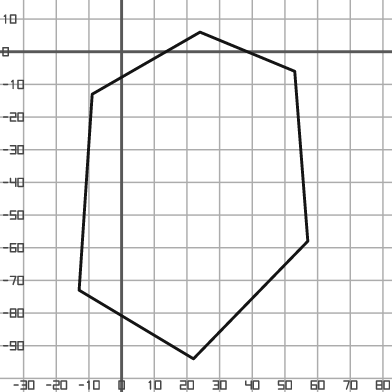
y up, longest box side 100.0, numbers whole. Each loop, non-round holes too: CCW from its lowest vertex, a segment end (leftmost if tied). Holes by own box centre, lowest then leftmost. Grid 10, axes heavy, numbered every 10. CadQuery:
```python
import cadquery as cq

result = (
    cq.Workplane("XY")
    .moveTo(22.0, -94.0)
    .lineTo(57.0, -58.0)
    .lineTo(53.0, -6.0)
    .lineTo(24.0, 6.0)
    .lineTo(-9.0, -13.0)
    .lineTo(-13.0, -73.0)
    .close()
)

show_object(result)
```